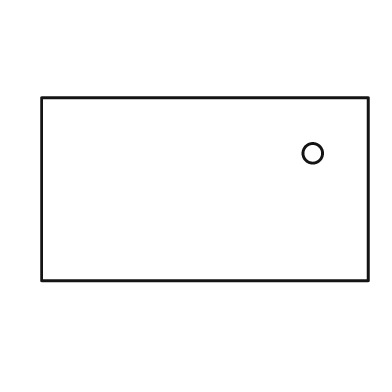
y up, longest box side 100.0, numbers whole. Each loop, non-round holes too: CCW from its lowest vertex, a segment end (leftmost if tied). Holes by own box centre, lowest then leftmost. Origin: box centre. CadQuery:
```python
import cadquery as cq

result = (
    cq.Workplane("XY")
    .moveTo(-50.0, -28.0)
    .lineTo(50.0, -28.0)
    .lineTo(50.0, 28.0)
    .lineTo(-50.0, 28.0)
    .close()
    .moveTo(33.0, 11.0)
    .circle(3.0)
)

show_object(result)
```